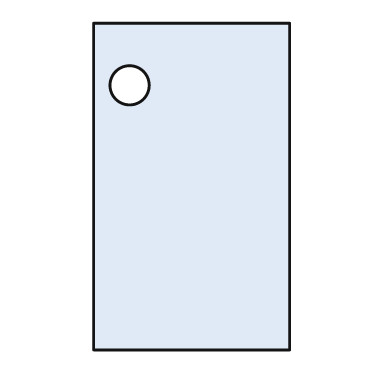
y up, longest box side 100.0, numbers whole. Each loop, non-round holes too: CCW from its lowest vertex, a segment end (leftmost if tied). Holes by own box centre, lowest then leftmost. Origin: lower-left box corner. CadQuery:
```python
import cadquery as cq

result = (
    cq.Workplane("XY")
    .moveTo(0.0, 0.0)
    .lineTo(60.0, 0.0)
    .lineTo(60.0, 100.0)
    .lineTo(0.0, 100.0)
    .close()
    .moveTo(11.0, 81.0)
    .circle(6.0)
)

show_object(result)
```